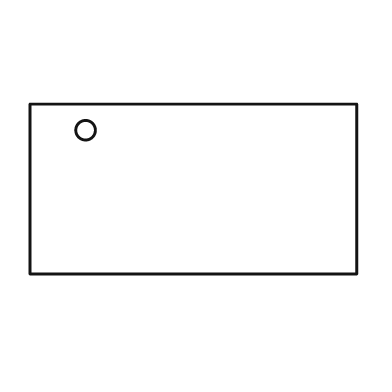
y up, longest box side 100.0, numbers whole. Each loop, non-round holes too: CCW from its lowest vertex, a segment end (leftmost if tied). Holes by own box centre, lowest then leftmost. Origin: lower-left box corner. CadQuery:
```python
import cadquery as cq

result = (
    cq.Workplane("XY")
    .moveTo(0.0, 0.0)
    .lineTo(100.0, 0.0)
    .lineTo(100.0, 52.0)
    .lineTo(0.0, 52.0)
    .close()
    .moveTo(17.0, 44.0)
    .circle(3.0)
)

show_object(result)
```